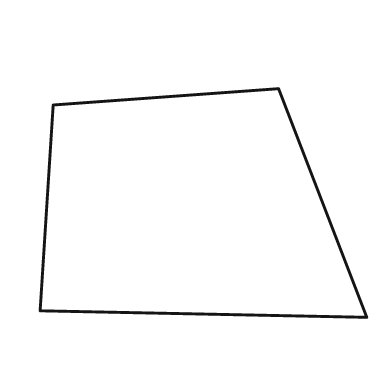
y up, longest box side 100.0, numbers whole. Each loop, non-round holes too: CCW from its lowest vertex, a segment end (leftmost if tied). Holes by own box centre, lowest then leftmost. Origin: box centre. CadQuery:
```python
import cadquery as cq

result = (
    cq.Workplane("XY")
    .moveTo(50.0, -35.0)
    .lineTo(23.0, 35.0)
    .lineTo(-46.0, 30.0)
    .lineTo(-50.0, -33.0)
    .close()
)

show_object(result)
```